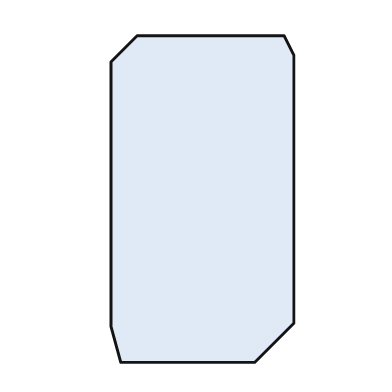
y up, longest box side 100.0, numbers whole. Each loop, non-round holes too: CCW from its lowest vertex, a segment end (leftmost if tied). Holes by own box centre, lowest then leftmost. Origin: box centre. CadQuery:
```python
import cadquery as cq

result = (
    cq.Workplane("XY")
    .moveTo(-25.0, -50.0)
    .lineTo(16.0, -50.0)
    .lineTo(28.0, -38.0)
    .lineTo(28.0, 44.0)
    .lineTo(25.0, 50.0)
    .lineTo(-20.0, 50.0)
    .lineTo(-28.0, 42.0)
    .lineTo(-28.0, -39.0)
    .close()
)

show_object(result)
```